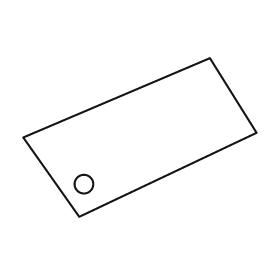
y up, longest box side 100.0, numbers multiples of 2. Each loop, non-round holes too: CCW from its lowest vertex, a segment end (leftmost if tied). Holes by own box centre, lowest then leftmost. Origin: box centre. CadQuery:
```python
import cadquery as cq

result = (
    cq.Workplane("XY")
    .moveTo(-26.0, -34.0)
    .lineTo(50.0, 2.0)
    .lineTo(30.0, 34.0)
    .lineTo(-50.0, 0.0)
    .close()
    .moveTo(-24.0, -20.0)
    .circle(4.0)
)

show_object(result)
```